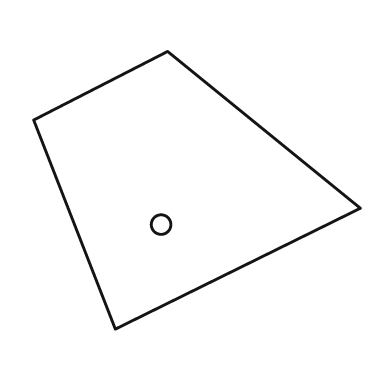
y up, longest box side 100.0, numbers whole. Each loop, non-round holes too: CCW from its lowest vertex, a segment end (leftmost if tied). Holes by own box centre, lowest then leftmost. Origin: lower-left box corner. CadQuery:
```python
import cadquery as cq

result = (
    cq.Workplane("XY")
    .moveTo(25.0, 0.0)
    .lineTo(100.0, 37.0)
    .lineTo(41.0, 85.0)
    .lineTo(0.0, 64.0)
    .close()
    .moveTo(39.0, 32.0)
    .circle(3.0)
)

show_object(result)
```